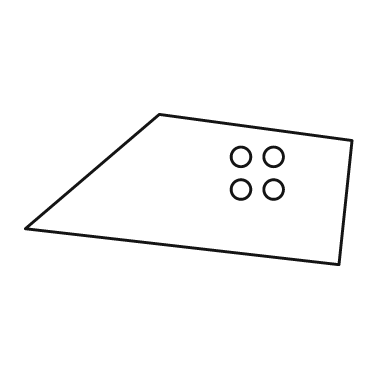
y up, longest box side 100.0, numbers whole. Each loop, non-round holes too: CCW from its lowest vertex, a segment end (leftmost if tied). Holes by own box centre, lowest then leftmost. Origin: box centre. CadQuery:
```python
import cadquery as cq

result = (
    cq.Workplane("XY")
    .moveTo(46.0, -23.0)
    .lineTo(50.0, 15.0)
    .lineTo(-9.0, 23.0)
    .lineTo(-50.0, -12.0)
    .close()
    .moveTo(16.0, 0.0)
    .circle(3.0)
    .moveTo(26.0, 0.0)
    .circle(3.0)
    .moveTo(16.0, 10.0)
    .circle(3.0)
    .moveTo(26.0, 10.0)
    .circle(3.0)
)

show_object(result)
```